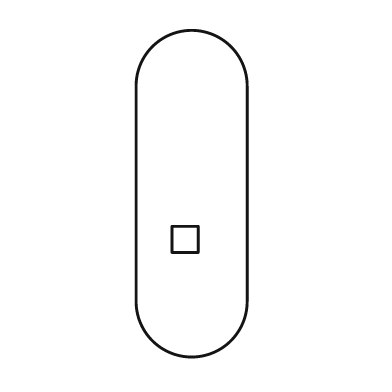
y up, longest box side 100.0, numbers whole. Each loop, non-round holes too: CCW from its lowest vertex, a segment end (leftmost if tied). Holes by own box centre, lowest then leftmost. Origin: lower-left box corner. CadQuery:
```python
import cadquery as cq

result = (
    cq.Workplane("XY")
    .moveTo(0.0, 17.0)
    .threePointArc((17.0, 0.0), (34.0, 17.0))
    .lineTo(34.0, 83.0)
    .threePointArc((17.0, 100.0), (0.0, 83.0))
    .close()
    .moveTo(11.0, 32.0)
    .lineTo(19.0, 32.0)
    .lineTo(19.0, 40.0)
    .lineTo(11.0, 40.0)
    .close()
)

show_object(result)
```